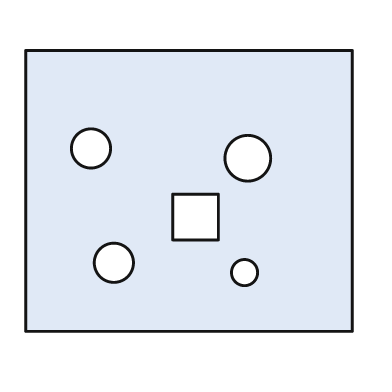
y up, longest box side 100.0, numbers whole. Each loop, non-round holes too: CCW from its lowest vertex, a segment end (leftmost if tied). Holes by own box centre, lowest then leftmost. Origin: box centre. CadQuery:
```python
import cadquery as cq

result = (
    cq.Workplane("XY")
    .moveTo(-50.0, -43.0)
    .lineTo(50.0, -43.0)
    .lineTo(50.0, 43.0)
    .lineTo(-50.0, 43.0)
    .close()
    .moveTo(17.0, -25.0)
    .circle(4.0)
    .moveTo(-23.0, -22.0)
    .circle(6.0)
    .moveTo(-5.0, -15.0)
    .lineTo(9.0, -15.0)
    .lineTo(9.0, -1.0)
    .lineTo(-5.0, -1.0)
    .close()
    .moveTo(18.0, 10.0)
    .circle(7.0)
    .moveTo(-30.0, 13.0)
    .circle(6.0)
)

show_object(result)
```